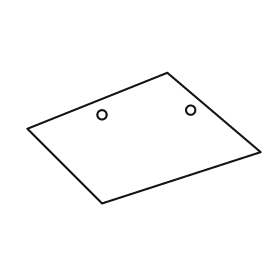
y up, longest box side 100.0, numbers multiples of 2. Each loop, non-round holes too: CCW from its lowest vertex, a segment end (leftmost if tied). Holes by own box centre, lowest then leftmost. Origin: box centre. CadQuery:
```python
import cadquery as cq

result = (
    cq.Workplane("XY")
    .moveTo(-18.0, -28.0)
    .lineTo(50.0, -6.0)
    .lineTo(10.0, 28.0)
    .lineTo(-50.0, 4.0)
    .close()
    .moveTo(-18.0, 10.0)
    .circle(2.0)
    .moveTo(20.0, 12.0)
    .circle(2.0)
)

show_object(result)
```